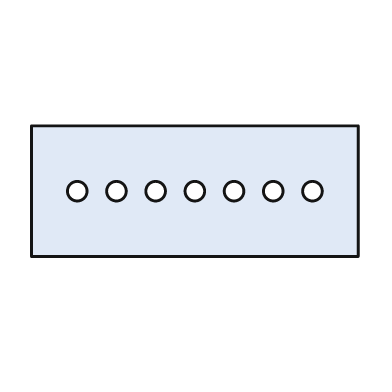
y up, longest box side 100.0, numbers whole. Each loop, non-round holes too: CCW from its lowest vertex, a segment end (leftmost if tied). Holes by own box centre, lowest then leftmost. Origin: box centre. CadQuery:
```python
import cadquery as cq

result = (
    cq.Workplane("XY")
    .moveTo(-50.0, -20.0)
    .lineTo(50.0, -20.0)
    .lineTo(50.0, 20.0)
    .lineTo(-50.0, 20.0)
    .close()
    .moveTo(-36.0, 0.0)
    .circle(3.0)
    .moveTo(-24.0, 0.0)
    .circle(3.0)
    .moveTo(-12.0, 0.0)
    .circle(3.0)
    .moveTo(0.0, 0.0)
    .circle(3.0)
    .moveTo(12.0, 0.0)
    .circle(3.0)
    .moveTo(24.0, 0.0)
    .circle(3.0)
    .moveTo(36.0, 0.0)
    .circle(3.0)
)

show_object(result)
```